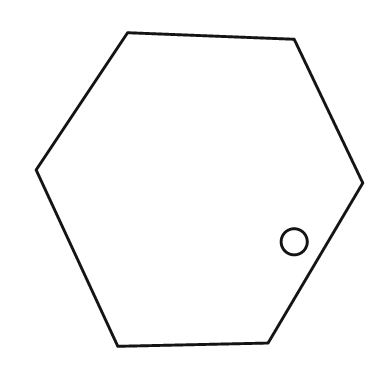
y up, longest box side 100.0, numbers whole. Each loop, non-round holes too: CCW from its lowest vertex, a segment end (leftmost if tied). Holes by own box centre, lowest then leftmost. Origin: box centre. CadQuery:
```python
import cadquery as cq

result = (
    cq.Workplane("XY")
    .moveTo(-25.0, -48.0)
    .lineTo(21.0, -47.0)
    .lineTo(50.0, 2.0)
    .lineTo(29.0, 46.0)
    .lineTo(-22.0, 48.0)
    .lineTo(-50.0, 6.0)
    .close()
    .moveTo(29.0, -16.0)
    .circle(4.0)
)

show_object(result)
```